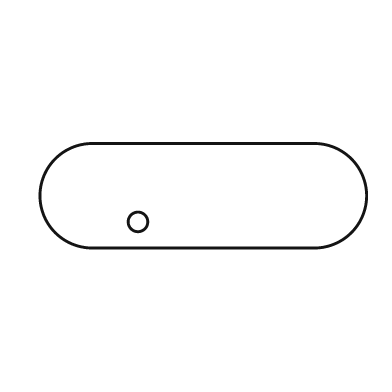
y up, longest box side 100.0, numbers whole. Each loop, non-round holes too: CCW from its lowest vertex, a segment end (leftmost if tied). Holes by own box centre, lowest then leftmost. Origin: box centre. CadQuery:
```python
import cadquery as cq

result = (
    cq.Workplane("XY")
    .moveTo(-34.0, -16.0)
    .lineTo(34.0, -16.0)
    .threePointArc((50.0, 0.0), (34.0, 16.0))
    .lineTo(-34.0, 16.0)
    .threePointArc((-50.0, 0.0), (-34.0, -16.0))
    .close()
    .moveTo(-20.0, -8.0)
    .circle(3.0)
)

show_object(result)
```